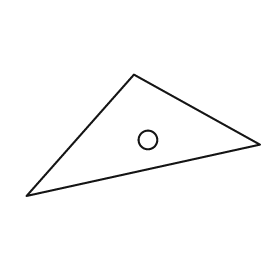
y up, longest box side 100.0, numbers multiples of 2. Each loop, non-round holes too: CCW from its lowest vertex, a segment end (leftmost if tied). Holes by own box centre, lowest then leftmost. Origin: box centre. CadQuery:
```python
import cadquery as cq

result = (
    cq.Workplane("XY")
    .moveTo(-50.0, -26.0)
    .lineTo(50.0, -4.0)
    .lineTo(-4.0, 26.0)
    .close()
    .moveTo(2.0, -2.0)
    .circle(4.0)
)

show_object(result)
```